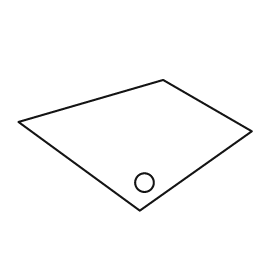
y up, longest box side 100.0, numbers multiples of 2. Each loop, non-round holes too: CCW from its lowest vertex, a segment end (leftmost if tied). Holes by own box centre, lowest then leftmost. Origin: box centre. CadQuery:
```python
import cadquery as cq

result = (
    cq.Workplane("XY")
    .moveTo(2.0, -28.0)
    .lineTo(50.0, 6.0)
    .lineTo(12.0, 28.0)
    .lineTo(-50.0, 10.0)
    .close()
    .moveTo(4.0, -16.0)
    .circle(4.0)
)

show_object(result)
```